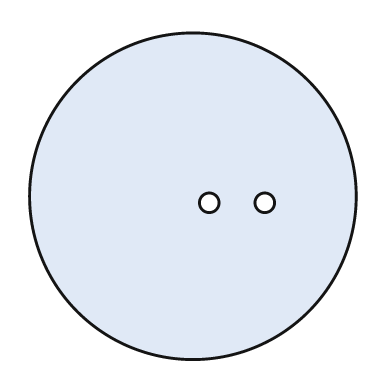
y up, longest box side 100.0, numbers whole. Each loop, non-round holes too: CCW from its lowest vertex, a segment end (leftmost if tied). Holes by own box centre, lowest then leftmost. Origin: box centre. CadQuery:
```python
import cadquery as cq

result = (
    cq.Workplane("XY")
    .moveTo(0.0, 0.0)
    .circle(50.0)
    .moveTo(5.0, -2.0)
    .circle(3.0)
    .moveTo(22.0, -2.0)
    .circle(3.0)
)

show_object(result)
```